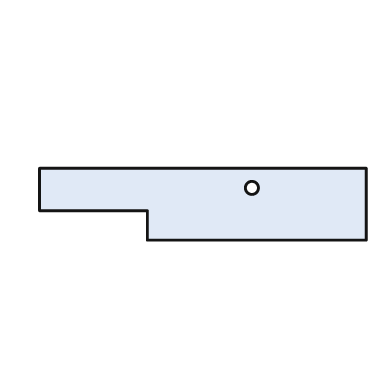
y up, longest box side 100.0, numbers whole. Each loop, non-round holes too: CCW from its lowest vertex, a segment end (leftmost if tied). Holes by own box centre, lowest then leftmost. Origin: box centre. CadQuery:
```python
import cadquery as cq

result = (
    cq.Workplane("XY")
    .moveTo(-17.0, -11.0)
    .lineTo(50.0, -11.0)
    .lineTo(50.0, 11.0)
    .lineTo(-50.0, 11.0)
    .lineTo(-50.0, -2.0)
    .lineTo(-17.0, -2.0)
    .close()
    .moveTo(15.0, 5.0)
    .circle(2.0)
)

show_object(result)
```